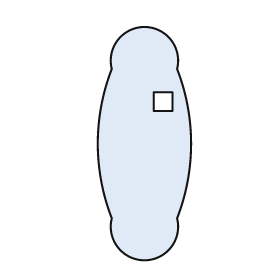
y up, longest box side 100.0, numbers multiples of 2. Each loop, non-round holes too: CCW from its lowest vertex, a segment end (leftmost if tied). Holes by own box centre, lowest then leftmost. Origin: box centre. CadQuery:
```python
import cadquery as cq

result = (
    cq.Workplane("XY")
    .moveTo(-14.0, -32.0)
    .threePointArc((0.0, -50.0), (14.0, -32.0))
    .threePointArc((20.0, 0.0), (14.0, 32.0))
    .threePointArc((0.0, 50.0), (-14.0, 32.0))
    .threePointArc((-20.0, 0.0), (-14.0, -32.0))
    .close()
    .moveTo(4.0, 14.0)
    .lineTo(12.0, 14.0)
    .lineTo(12.0, 22.0)
    .lineTo(4.0, 22.0)
    .close()
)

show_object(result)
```